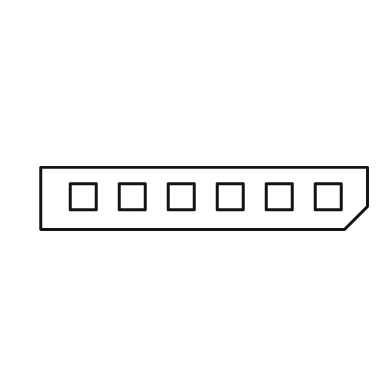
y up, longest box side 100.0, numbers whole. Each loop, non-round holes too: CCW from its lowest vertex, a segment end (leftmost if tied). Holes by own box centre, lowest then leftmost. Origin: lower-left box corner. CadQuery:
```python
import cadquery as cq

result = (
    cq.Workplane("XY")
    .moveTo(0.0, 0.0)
    .lineTo(93.0, 0.0)
    .lineTo(100.0, 7.0)
    .lineTo(100.0, 19.0)
    .lineTo(0.0, 19.0)
    .close()
    .moveTo(9.0, 6.0)
    .lineTo(17.0, 6.0)
    .lineTo(17.0, 14.0)
    .lineTo(9.0, 14.0)
    .close()
    .moveTo(24.0, 6.0)
    .lineTo(32.0, 6.0)
    .lineTo(32.0, 14.0)
    .lineTo(24.0, 14.0)
    .close()
    .moveTo(39.0, 6.0)
    .lineTo(47.0, 6.0)
    .lineTo(47.0, 14.0)
    .lineTo(39.0, 14.0)
    .close()
    .moveTo(54.0, 6.0)
    .lineTo(62.0, 6.0)
    .lineTo(62.0, 14.0)
    .lineTo(54.0, 14.0)
    .close()
    .moveTo(69.0, 6.0)
    .lineTo(77.0, 6.0)
    .lineTo(77.0, 14.0)
    .lineTo(69.0, 14.0)
    .close()
    .moveTo(84.0, 6.0)
    .lineTo(92.0, 6.0)
    .lineTo(92.0, 14.0)
    .lineTo(84.0, 14.0)
    .close()
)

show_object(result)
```